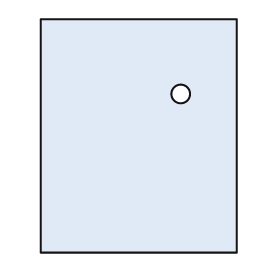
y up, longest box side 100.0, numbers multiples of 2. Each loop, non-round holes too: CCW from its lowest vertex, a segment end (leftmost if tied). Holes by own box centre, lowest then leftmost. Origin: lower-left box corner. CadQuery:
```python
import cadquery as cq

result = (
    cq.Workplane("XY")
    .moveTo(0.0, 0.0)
    .lineTo(84.0, 0.0)
    .lineTo(84.0, 100.0)
    .lineTo(0.0, 100.0)
    .close()
    .moveTo(60.0, 68.0)
    .circle(4.0)
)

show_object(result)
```